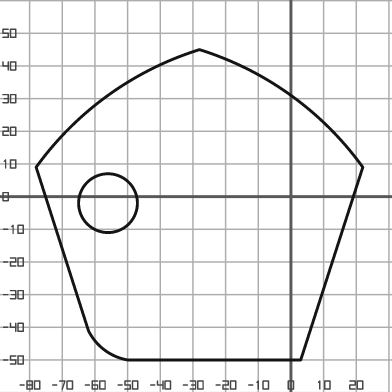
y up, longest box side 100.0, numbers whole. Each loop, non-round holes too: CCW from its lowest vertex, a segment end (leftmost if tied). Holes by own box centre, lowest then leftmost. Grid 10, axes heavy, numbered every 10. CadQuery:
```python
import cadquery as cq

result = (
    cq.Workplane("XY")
    .moveTo(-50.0, -50.0)
    .lineTo(3.0, -50.0)
    .lineTo(22.0, 9.0)
    .threePointArc((0.0, 31.0), (-28.0, 45.0))
    .threePointArc((-56.0, 31.0), (-78.0, 9.0))
    .lineTo(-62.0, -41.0)
    .threePointArc((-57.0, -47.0), (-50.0, -50.0))
    .close()
    .moveTo(-56.0, -2.0)
    .circle(9.0)
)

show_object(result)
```